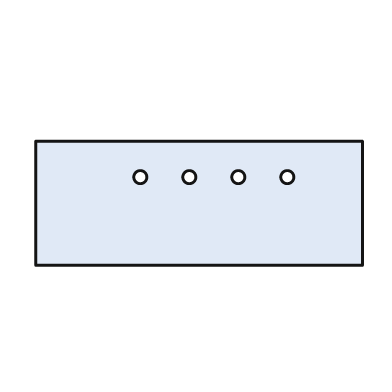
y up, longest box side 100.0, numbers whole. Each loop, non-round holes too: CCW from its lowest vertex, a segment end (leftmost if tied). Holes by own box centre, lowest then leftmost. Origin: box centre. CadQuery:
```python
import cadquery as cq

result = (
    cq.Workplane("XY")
    .moveTo(-50.0, -19.0)
    .lineTo(50.0, -19.0)
    .lineTo(50.0, 19.0)
    .lineTo(-50.0, 19.0)
    .close()
    .moveTo(-18.0, 8.0)
    .circle(2.0)
    .moveTo(-3.0, 8.0)
    .circle(2.0)
    .moveTo(12.0, 8.0)
    .circle(2.0)
    .moveTo(27.0, 8.0)
    .circle(2.0)
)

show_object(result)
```